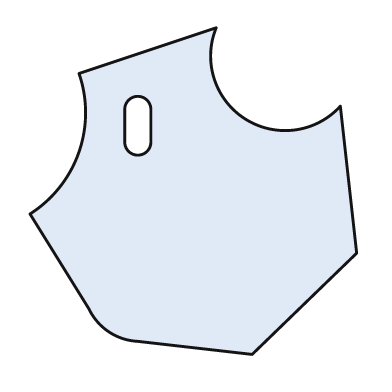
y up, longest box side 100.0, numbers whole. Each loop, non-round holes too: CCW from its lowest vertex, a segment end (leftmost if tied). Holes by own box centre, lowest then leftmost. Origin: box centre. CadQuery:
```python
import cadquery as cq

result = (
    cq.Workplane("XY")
    .moveTo(18.0, -50.0)
    .lineTo(50.0, -19.0)
    .lineTo(45.0, 26.0)
    .threePointArc((16.0, 22.0), (7.0, 50.0))
    .lineTo(-35.0, 36.0)
    .threePointArc((-35.0, 12.0), (-50.0, -7.0))
    .lineTo(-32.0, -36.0)
    .threePointArc((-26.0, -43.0), (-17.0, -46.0))
    .close()
    .moveTo(-21.0, 15.0)
    .threePointArc((-17.0, 11.0), (-13.0, 15.0))
    .lineTo(-13.0, 25.0)
    .threePointArc((-17.0, 29.0), (-21.0, 25.0))
    .close()
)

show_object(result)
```